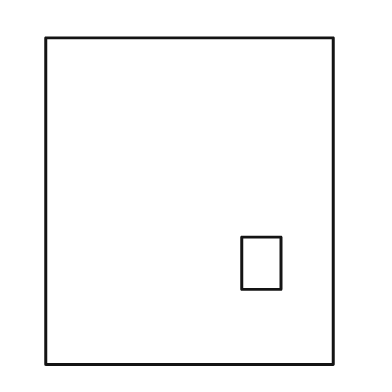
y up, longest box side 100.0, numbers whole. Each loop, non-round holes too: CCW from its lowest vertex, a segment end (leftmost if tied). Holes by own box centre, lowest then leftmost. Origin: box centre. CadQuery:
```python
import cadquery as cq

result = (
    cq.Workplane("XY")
    .moveTo(-44.0, -50.0)
    .lineTo(44.0, -50.0)
    .lineTo(44.0, 50.0)
    .lineTo(-44.0, 50.0)
    .close()
    .moveTo(16.0, -27.0)
    .lineTo(28.0, -27.0)
    .lineTo(28.0, -11.0)
    .lineTo(16.0, -11.0)
    .close()
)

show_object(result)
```